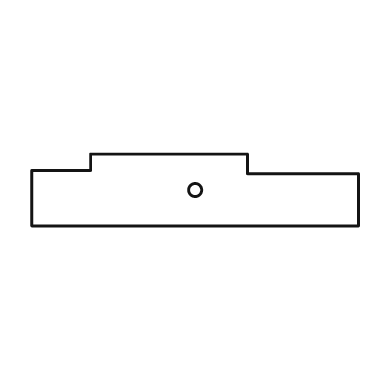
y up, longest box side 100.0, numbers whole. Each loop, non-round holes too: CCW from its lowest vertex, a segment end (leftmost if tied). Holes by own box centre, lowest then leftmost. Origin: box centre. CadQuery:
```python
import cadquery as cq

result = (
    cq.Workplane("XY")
    .moveTo(-50.0, -11.0)
    .lineTo(50.0, -11.0)
    .lineTo(50.0, 5.0)
    .lineTo(16.0, 5.0)
    .lineTo(16.0, 11.0)
    .lineTo(-32.0, 11.0)
    .lineTo(-32.0, 6.0)
    .lineTo(-50.0, 6.0)
    .close()
    .moveTo(0.0, 0.0)
    .circle(2.0)
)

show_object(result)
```